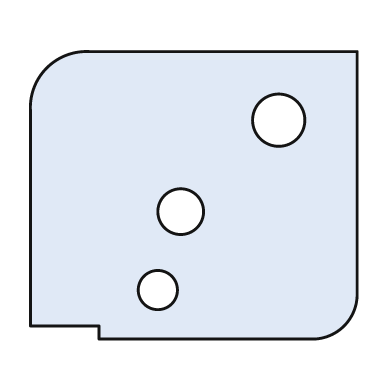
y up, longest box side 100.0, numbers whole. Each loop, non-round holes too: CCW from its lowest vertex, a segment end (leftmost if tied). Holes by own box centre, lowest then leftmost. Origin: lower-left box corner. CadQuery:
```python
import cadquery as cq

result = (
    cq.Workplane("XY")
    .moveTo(21.0, 0.0)
    .lineTo(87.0, 0.0)
    .threePointArc((96.0, 4.0), (100.0, 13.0))
    .lineTo(100.0, 88.0)
    .lineTo(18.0, 88.0)
    .threePointArc((5.0, 83.0), (0.0, 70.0))
    .lineTo(0.0, 4.0)
    .lineTo(21.0, 4.0)
    .close()
    .moveTo(39.0, 15.0)
    .circle(6.0)
    .moveTo(46.0, 39.0)
    .circle(7.0)
    .moveTo(76.0, 67.0)
    .circle(8.0)
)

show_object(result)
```